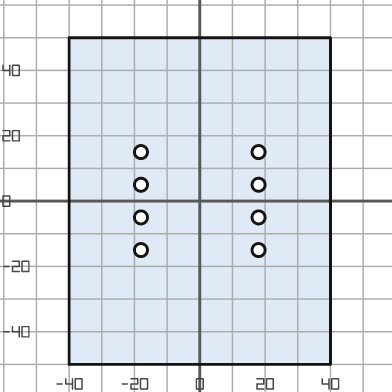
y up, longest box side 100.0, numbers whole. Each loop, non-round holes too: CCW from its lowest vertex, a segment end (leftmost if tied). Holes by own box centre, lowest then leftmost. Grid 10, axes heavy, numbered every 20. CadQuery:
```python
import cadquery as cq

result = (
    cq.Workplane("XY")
    .moveTo(-40.0, -50.0)
    .lineTo(40.0, -50.0)
    .lineTo(40.0, 50.0)
    .lineTo(-40.0, 50.0)
    .close()
    .moveTo(-18.0, -15.0)
    .circle(2.0)
    .moveTo(18.0, -15.0)
    .circle(2.0)
    .moveTo(-18.0, -5.0)
    .circle(2.0)
    .moveTo(18.0, -5.0)
    .circle(2.0)
    .moveTo(-18.0, 5.0)
    .circle(2.0)
    .moveTo(18.0, 5.0)
    .circle(2.0)
    .moveTo(-18.0, 15.0)
    .circle(2.0)
    .moveTo(18.0, 15.0)
    .circle(2.0)
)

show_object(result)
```